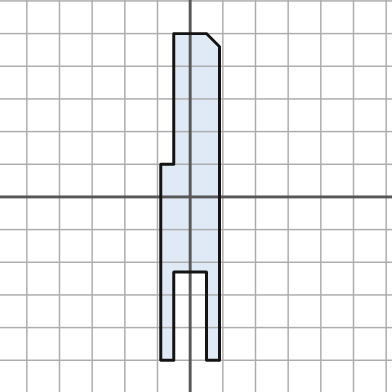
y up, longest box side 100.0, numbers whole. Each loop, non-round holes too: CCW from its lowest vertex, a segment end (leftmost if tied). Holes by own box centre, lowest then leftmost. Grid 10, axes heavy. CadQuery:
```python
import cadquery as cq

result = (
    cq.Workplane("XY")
    .moveTo(-9.0, -50.0)
    .lineTo(-5.0, -50.0)
    .lineTo(-5.0, -23.0)
    .lineTo(5.0, -23.0)
    .lineTo(5.0, -50.0)
    .lineTo(9.0, -50.0)
    .lineTo(9.0, 46.0)
    .lineTo(5.0, 50.0)
    .lineTo(-5.0, 50.0)
    .lineTo(-5.0, 10.0)
    .lineTo(-9.0, 10.0)
    .close()
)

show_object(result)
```